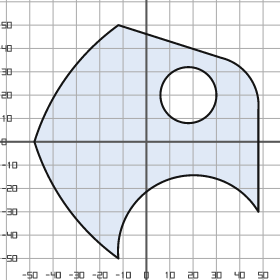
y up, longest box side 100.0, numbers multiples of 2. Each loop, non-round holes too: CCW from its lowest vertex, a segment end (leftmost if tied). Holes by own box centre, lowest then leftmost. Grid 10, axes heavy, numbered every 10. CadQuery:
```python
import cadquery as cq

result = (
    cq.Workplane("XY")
    .moveTo(-12.0, -50.0)
    .threePointArc((10.0, -16.0), (48.0, -30.0))
    .lineTo(48.0, 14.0)
    .threePointArc((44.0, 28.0), (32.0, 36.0))
    .lineTo(-12.0, 50.0)
    .threePointArc((-34.0, 28.0), (-48.0, 0.0))
    .threePointArc((-34.0, -28.0), (-12.0, -50.0))
    .close()
    .moveTo(18.0, 20.0)
    .circle(12.0)
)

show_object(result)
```